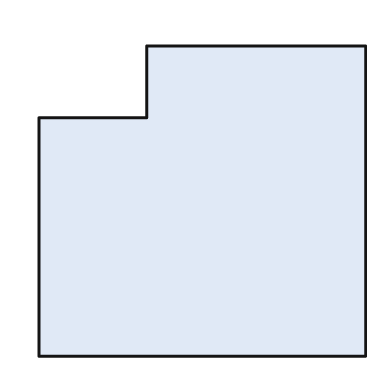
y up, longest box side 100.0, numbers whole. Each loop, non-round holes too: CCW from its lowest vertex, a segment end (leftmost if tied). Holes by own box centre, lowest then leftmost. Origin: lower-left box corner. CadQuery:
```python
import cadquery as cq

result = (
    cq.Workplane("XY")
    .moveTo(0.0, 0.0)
    .lineTo(100.0, 0.0)
    .lineTo(100.0, 95.0)
    .lineTo(33.0, 95.0)
    .lineTo(33.0, 73.0)
    .lineTo(0.0, 73.0)
    .close()
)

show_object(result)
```